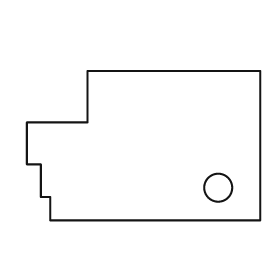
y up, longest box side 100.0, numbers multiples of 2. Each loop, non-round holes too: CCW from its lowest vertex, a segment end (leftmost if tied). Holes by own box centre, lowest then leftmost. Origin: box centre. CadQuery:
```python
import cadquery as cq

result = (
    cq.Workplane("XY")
    .moveTo(-40.0, -32.0)
    .lineTo(50.0, -32.0)
    .lineTo(50.0, 32.0)
    .lineTo(-24.0, 32.0)
    .lineTo(-24.0, 10.0)
    .lineTo(-50.0, 10.0)
    .lineTo(-50.0, -8.0)
    .lineTo(-44.0, -8.0)
    .lineTo(-44.0, -22.0)
    .lineTo(-40.0, -22.0)
    .close()
    .moveTo(32.0, -18.0)
    .circle(6.0)
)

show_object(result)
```